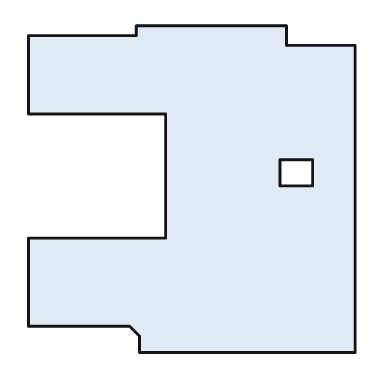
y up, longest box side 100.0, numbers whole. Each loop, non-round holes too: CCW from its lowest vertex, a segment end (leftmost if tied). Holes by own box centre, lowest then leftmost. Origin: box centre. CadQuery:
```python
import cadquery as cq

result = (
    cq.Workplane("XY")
    .moveTo(-16.0, -50.0)
    .lineTo(50.0, -50.0)
    .lineTo(50.0, 44.0)
    .lineTo(29.0, 44.0)
    .lineTo(29.0, 50.0)
    .lineTo(-17.0, 50.0)
    .lineTo(-17.0, 47.0)
    .lineTo(-50.0, 47.0)
    .lineTo(-50.0, 23.0)
    .lineTo(-8.0, 23.0)
    .lineTo(-8.0, -15.0)
    .lineTo(-50.0, -15.0)
    .lineTo(-50.0, -42.0)
    .lineTo(-19.0, -42.0)
    .lineTo(-16.0, -45.0)
    .close()
    .moveTo(27.0, 1.0)
    .lineTo(37.0, 1.0)
    .lineTo(37.0, 9.0)
    .lineTo(27.0, 9.0)
    .close()
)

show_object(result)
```